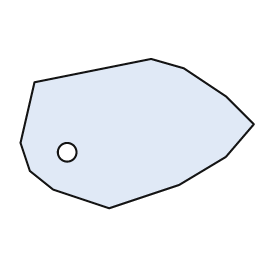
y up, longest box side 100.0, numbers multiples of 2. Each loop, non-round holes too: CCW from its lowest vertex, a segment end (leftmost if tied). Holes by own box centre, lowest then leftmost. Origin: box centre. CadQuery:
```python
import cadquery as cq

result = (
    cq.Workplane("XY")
    .moveTo(-12.0, -32.0)
    .lineTo(18.0, -22.0)
    .lineTo(38.0, -10.0)
    .lineTo(50.0, 4.0)
    .lineTo(38.0, 16.0)
    .lineTo(20.0, 28.0)
    .lineTo(6.0, 32.0)
    .lineTo(-44.0, 22.0)
    .lineTo(-50.0, -4.0)
    .lineTo(-46.0, -16.0)
    .lineTo(-36.0, -24.0)
    .close()
    .moveTo(-30.0, -8.0)
    .circle(4.0)
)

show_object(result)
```